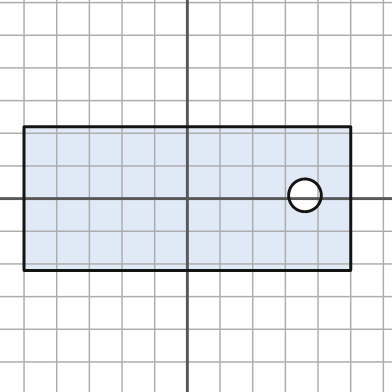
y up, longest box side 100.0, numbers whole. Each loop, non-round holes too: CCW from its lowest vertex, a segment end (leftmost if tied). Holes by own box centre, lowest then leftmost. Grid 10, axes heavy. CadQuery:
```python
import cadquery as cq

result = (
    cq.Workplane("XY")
    .moveTo(-50.0, -22.0)
    .lineTo(50.0, -22.0)
    .lineTo(50.0, 22.0)
    .lineTo(-50.0, 22.0)
    .close()
    .moveTo(36.0, 1.0)
    .circle(5.0)
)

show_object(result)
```